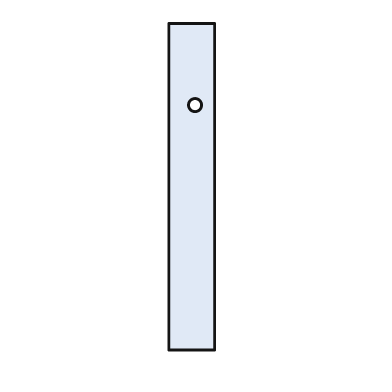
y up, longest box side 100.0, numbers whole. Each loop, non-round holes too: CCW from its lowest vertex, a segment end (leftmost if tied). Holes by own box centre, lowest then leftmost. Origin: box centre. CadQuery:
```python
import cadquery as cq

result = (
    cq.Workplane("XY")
    .moveTo(-7.0, -50.0)
    .lineTo(7.0, -50.0)
    .lineTo(7.0, 50.0)
    .lineTo(-7.0, 50.0)
    .close()
    .moveTo(1.0, 25.0)
    .circle(2.0)
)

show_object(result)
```